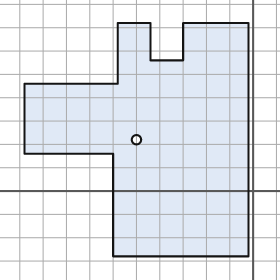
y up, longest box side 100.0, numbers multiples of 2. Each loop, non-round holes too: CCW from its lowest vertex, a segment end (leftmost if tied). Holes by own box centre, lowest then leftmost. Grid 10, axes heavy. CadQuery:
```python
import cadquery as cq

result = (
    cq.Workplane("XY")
    .moveTo(-60.0, -28.0)
    .lineTo(-2.0, -28.0)
    .lineTo(-2.0, 72.0)
    .lineTo(-30.0, 72.0)
    .lineTo(-30.0, 56.0)
    .lineTo(-44.0, 56.0)
    .lineTo(-44.0, 72.0)
    .lineTo(-58.0, 72.0)
    .lineTo(-58.0, 46.0)
    .lineTo(-98.0, 46.0)
    .lineTo(-98.0, 16.0)
    .lineTo(-60.0, 16.0)
    .close()
    .moveTo(-50.0, 22.0)
    .circle(2.0)
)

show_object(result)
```